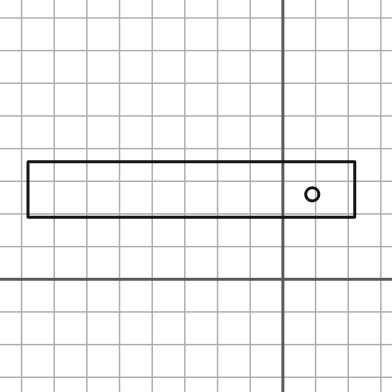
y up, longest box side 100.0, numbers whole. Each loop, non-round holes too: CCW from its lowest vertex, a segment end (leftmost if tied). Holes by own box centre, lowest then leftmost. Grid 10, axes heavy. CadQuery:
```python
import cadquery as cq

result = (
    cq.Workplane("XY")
    .moveTo(-78.0, 19.0)
    .lineTo(22.0, 19.0)
    .lineTo(22.0, 36.0)
    .lineTo(-78.0, 36.0)
    .close()
    .moveTo(9.0, 26.0)
    .circle(2.0)
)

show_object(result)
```